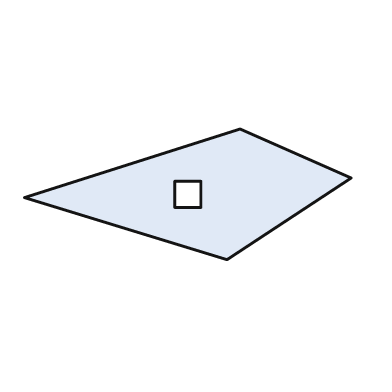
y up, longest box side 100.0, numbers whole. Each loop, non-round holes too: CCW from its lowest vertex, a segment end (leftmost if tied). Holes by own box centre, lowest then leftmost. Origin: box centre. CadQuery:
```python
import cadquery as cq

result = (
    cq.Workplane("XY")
    .moveTo(12.0, -20.0)
    .lineTo(50.0, 5.0)
    .lineTo(16.0, 20.0)
    .lineTo(-50.0, -1.0)
    .close()
    .moveTo(-4.0, -4.0)
    .lineTo(4.0, -4.0)
    .lineTo(4.0, 4.0)
    .lineTo(-4.0, 4.0)
    .close()
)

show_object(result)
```